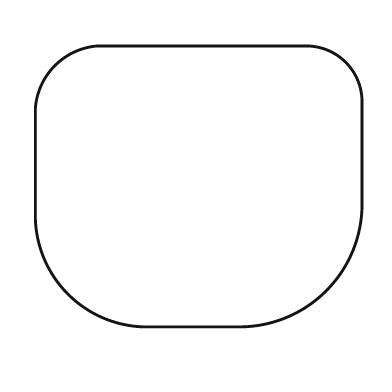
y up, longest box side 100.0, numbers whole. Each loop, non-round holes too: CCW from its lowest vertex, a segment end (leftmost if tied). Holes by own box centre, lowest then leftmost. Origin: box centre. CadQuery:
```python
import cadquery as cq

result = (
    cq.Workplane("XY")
    .moveTo(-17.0, -43.0)
    .lineTo(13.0, -43.0)
    .threePointArc((39.0, -32.0), (50.0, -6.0))
    .lineTo(50.0, 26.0)
    .threePointArc((45.0, 38.0), (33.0, 43.0))
    .lineTo(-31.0, 43.0)
    .threePointArc((-44.0, 37.0), (-50.0, 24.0))
    .lineTo(-50.0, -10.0)
    .threePointArc((-40.0, -33.0), (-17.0, -43.0))
    .close()
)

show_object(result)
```